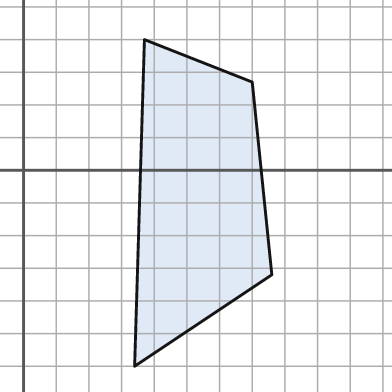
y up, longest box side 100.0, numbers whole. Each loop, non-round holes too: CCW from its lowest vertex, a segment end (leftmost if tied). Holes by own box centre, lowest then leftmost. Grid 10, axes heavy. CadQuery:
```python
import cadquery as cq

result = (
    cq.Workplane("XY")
    .moveTo(34.0, -60.0)
    .lineTo(76.0, -32.0)
    .lineTo(70.0, 27.0)
    .lineTo(37.0, 40.0)
    .close()
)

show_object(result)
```